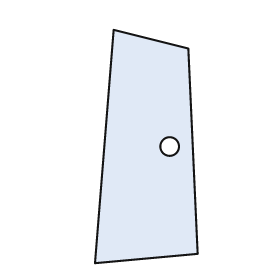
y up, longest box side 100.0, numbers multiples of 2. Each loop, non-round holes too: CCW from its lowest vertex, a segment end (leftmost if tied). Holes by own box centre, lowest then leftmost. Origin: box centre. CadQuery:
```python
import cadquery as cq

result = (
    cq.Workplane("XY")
    .moveTo(-22.0, -50.0)
    .lineTo(22.0, -46.0)
    .lineTo(18.0, 42.0)
    .lineTo(-14.0, 50.0)
    .close()
    .moveTo(10.0, 0.0)
    .circle(4.0)
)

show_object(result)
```